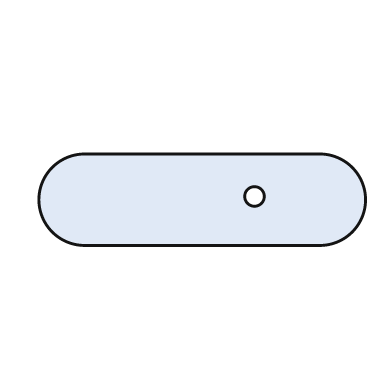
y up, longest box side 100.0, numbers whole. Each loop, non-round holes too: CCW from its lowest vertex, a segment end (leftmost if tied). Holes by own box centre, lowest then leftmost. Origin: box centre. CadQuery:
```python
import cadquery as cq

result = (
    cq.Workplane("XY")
    .moveTo(-36.0, -14.0)
    .lineTo(36.0, -14.0)
    .threePointArc((50.0, 0.0), (36.0, 14.0))
    .lineTo(-36.0, 14.0)
    .threePointArc((-50.0, 0.0), (-36.0, -14.0))
    .close()
    .moveTo(16.0, 1.0)
    .circle(3.0)
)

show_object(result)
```